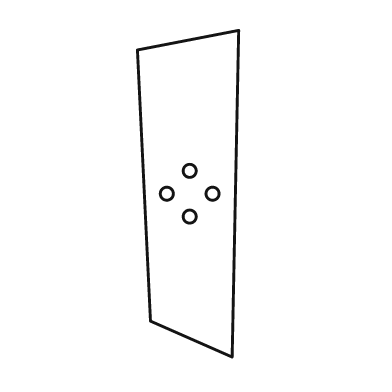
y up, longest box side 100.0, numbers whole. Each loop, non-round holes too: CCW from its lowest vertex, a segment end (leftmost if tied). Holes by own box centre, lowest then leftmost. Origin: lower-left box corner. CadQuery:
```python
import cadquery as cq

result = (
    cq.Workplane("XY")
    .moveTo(29.0, 0.0)
    .lineTo(31.0, 100.0)
    .lineTo(0.0, 94.0)
    .lineTo(4.0, 11.0)
    .close()
    .moveTo(16.0, 43.0)
    .circle(2.0)
    .moveTo(9.0, 50.0)
    .circle(2.0)
    .moveTo(23.0, 50.0)
    .circle(2.0)
    .moveTo(16.0, 57.0)
    .circle(2.0)
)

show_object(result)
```